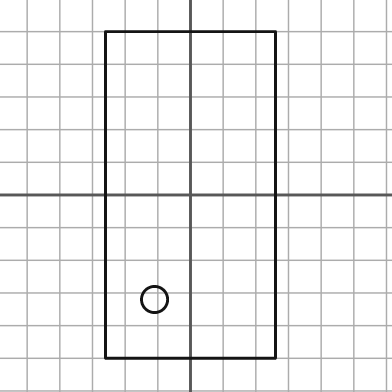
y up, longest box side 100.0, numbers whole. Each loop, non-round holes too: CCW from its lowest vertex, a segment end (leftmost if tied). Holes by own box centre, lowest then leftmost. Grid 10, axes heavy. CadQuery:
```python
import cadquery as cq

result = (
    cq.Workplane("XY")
    .moveTo(-26.0, -50.0)
    .lineTo(26.0, -50.0)
    .lineTo(26.0, 50.0)
    .lineTo(-26.0, 50.0)
    .close()
    .moveTo(-11.0, -32.0)
    .circle(4.0)
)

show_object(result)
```